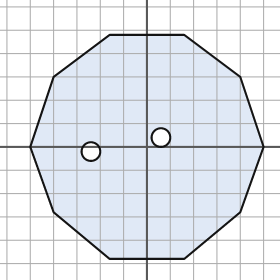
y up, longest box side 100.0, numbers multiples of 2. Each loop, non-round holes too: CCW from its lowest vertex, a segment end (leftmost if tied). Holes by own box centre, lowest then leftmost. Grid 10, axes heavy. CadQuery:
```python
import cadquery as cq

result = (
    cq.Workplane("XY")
    .moveTo(-16.0, -48.0)
    .lineTo(16.0, -48.0)
    .lineTo(40.0, -28.0)
    .lineTo(50.0, 0.0)
    .lineTo(40.0, 30.0)
    .lineTo(16.0, 48.0)
    .lineTo(-16.0, 48.0)
    .lineTo(-40.0, 30.0)
    .lineTo(-50.0, 0.0)
    .lineTo(-40.0, -28.0)
    .close()
    .moveTo(-24.0, -2.0)
    .circle(4.0)
    .moveTo(6.0, 4.0)
    .circle(4.0)
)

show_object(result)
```